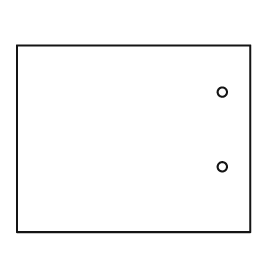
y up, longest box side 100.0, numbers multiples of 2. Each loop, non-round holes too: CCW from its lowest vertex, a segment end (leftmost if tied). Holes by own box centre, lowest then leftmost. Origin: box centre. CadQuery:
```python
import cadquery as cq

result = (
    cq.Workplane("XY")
    .moveTo(-50.0, -40.0)
    .lineTo(50.0, -40.0)
    .lineTo(50.0, 40.0)
    .lineTo(-50.0, 40.0)
    .close()
    .moveTo(38.0, -12.0)
    .circle(2.0)
    .moveTo(38.0, 20.0)
    .circle(2.0)
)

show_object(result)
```